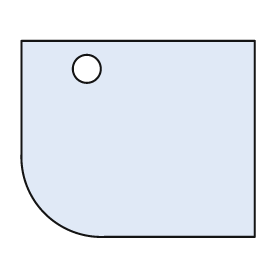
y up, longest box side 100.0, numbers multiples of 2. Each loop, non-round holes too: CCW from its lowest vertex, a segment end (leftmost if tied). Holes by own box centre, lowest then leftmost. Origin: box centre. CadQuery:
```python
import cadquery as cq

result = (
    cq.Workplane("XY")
    .moveTo(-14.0, -42.0)
    .lineTo(50.0, -42.0)
    .lineTo(50.0, 42.0)
    .lineTo(-50.0, 42.0)
    .lineTo(-50.0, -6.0)
    .threePointArc((-40.0, -32.0), (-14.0, -42.0))
    .close()
    .moveTo(-22.0, 30.0)
    .circle(6.0)
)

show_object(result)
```